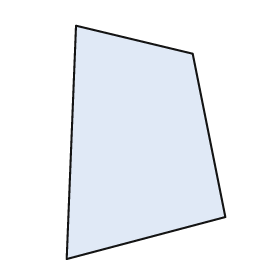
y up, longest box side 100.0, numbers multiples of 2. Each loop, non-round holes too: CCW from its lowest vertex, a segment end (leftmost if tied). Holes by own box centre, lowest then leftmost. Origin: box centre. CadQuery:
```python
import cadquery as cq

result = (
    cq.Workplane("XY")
    .moveTo(-34.0, -50.0)
    .lineTo(34.0, -32.0)
    .lineTo(20.0, 38.0)
    .lineTo(-30.0, 50.0)
    .close()
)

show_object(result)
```